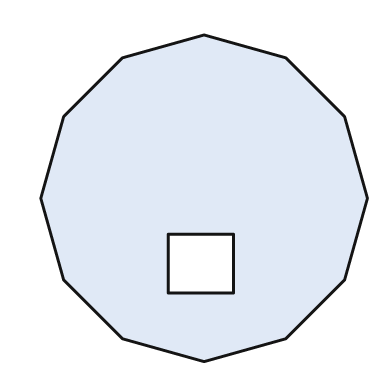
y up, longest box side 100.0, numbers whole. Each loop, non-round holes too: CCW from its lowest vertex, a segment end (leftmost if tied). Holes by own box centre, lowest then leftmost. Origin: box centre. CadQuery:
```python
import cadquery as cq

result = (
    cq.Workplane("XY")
    .moveTo(0.0, -50.0)
    .lineTo(25.0, -43.0)
    .lineTo(43.0, -25.0)
    .lineTo(50.0, 0.0)
    .lineTo(43.0, 25.0)
    .lineTo(25.0, 43.0)
    .lineTo(0.0, 50.0)
    .lineTo(-25.0, 43.0)
    .lineTo(-43.0, 25.0)
    .lineTo(-50.0, 0.0)
    .lineTo(-43.0, -25.0)
    .lineTo(-25.0, -43.0)
    .close()
    .moveTo(-11.0, -29.0)
    .lineTo(9.0, -29.0)
    .lineTo(9.0, -11.0)
    .lineTo(-11.0, -11.0)
    .close()
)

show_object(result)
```